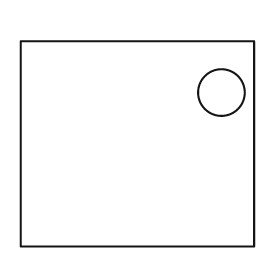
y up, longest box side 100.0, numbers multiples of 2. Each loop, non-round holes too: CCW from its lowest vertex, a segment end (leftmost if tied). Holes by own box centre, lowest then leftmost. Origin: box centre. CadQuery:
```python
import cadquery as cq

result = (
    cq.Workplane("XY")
    .moveTo(-50.0, -44.0)
    .lineTo(50.0, -44.0)
    .lineTo(50.0, 44.0)
    .lineTo(-50.0, 44.0)
    .close()
    .moveTo(36.0, 22.0)
    .circle(10.0)
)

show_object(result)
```